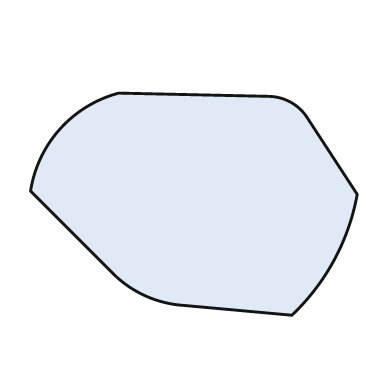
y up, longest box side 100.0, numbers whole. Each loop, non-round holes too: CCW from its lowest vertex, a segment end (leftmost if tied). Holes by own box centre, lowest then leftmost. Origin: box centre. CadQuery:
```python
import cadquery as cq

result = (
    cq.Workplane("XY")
    .moveTo(30.0, -34.0)
    .threePointArc((43.0, -17.0), (50.0, 3.0))
    .lineTo(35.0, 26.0)
    .threePointArc((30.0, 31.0), (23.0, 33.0))
    .lineTo(-23.0, 34.0)
    .threePointArc((-41.0, 23.0), (-50.0, 4.0))
    .lineTo(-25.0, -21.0)
    .threePointArc((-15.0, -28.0), (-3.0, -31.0))
    .close()
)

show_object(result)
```